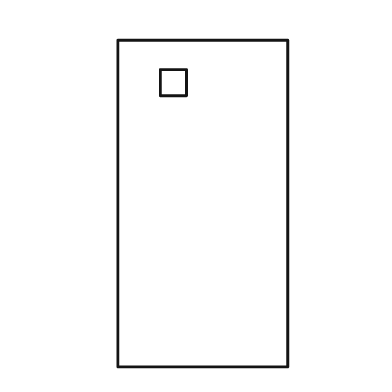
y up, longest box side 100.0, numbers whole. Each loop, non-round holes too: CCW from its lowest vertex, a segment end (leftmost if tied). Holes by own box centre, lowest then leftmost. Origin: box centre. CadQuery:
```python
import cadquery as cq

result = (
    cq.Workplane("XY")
    .moveTo(-26.0, -50.0)
    .lineTo(26.0, -50.0)
    .lineTo(26.0, 50.0)
    .lineTo(-26.0, 50.0)
    .close()
    .moveTo(-13.0, 33.0)
    .lineTo(-5.0, 33.0)
    .lineTo(-5.0, 41.0)
    .lineTo(-13.0, 41.0)
    .close()
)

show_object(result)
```